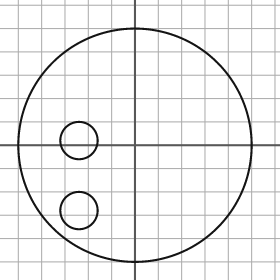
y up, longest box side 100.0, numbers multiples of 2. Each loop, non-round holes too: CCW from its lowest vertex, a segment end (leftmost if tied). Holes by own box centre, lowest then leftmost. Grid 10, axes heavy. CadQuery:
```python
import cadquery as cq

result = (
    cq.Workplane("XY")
    .moveTo(0.0, 0.0)
    .circle(50.0)
    .moveTo(-24.0, -28.0)
    .circle(8.0)
    .moveTo(-24.0, 2.0)
    .circle(8.0)
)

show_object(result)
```